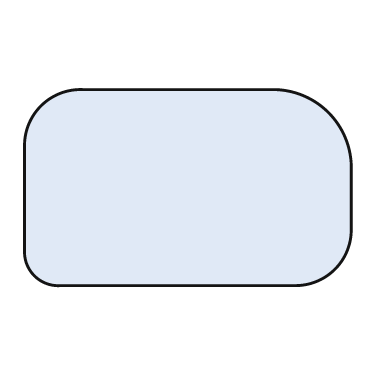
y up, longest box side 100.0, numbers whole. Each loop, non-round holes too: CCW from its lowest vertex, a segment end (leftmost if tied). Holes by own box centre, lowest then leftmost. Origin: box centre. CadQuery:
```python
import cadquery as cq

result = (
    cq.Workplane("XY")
    .moveTo(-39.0, -30.0)
    .lineTo(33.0, -30.0)
    .threePointArc((45.0, -25.0), (50.0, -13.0))
    .lineTo(50.0, 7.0)
    .threePointArc((43.0, 23.0), (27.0, 30.0))
    .lineTo(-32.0, 30.0)
    .threePointArc((-45.0, 25.0), (-50.0, 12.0))
    .lineTo(-50.0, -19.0)
    .threePointArc((-47.0, -27.0), (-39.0, -30.0))
    .close()
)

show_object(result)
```